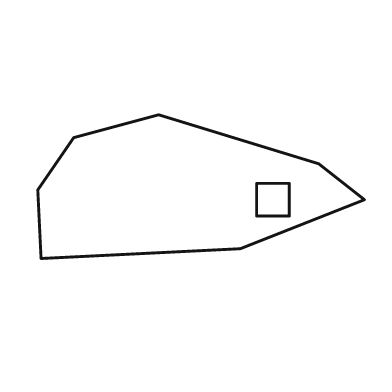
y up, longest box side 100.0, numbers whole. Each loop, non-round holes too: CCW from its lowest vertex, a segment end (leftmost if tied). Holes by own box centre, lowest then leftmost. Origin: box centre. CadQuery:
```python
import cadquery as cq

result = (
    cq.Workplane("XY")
    .moveTo(-49.0, -22.0)
    .lineTo(12.0, -19.0)
    .lineTo(50.0, -4.0)
    .lineTo(36.0, 7.0)
    .lineTo(-13.0, 22.0)
    .lineTo(-39.0, 15.0)
    .lineTo(-50.0, -1.0)
    .close()
    .moveTo(17.0, -9.0)
    .lineTo(27.0, -9.0)
    .lineTo(27.0, 1.0)
    .lineTo(17.0, 1.0)
    .close()
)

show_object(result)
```